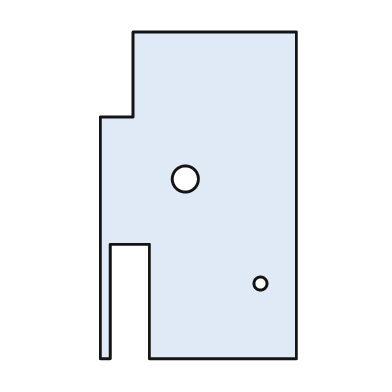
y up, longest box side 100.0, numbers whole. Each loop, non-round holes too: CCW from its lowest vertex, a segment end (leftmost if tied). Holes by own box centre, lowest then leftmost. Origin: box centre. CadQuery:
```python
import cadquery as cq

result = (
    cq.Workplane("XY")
    .moveTo(-30.0, -50.0)
    .lineTo(-27.0, -50.0)
    .lineTo(-27.0, -15.0)
    .lineTo(-15.0, -15.0)
    .lineTo(-15.0, -50.0)
    .lineTo(30.0, -50.0)
    .lineTo(30.0, 50.0)
    .lineTo(-20.0, 50.0)
    .lineTo(-20.0, 24.0)
    .lineTo(-30.0, 24.0)
    .close()
    .moveTo(19.0, -27.0)
    .circle(2.0)
    .moveTo(-4.0, 5.0)
    .circle(4.0)
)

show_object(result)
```